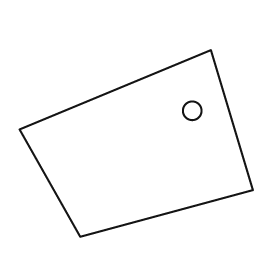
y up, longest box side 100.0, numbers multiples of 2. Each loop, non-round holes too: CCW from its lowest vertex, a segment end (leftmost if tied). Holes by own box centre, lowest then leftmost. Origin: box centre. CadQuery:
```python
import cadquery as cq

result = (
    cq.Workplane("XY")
    .moveTo(-24.0, -40.0)
    .lineTo(50.0, -20.0)
    .lineTo(32.0, 40.0)
    .lineTo(-50.0, 6.0)
    .close()
    .moveTo(24.0, 14.0)
    .circle(4.0)
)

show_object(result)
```